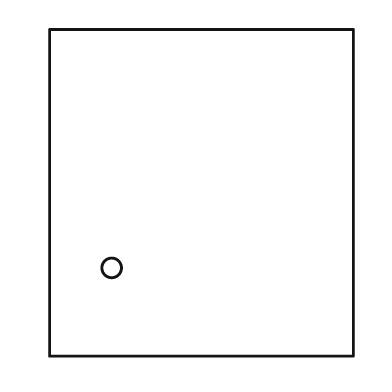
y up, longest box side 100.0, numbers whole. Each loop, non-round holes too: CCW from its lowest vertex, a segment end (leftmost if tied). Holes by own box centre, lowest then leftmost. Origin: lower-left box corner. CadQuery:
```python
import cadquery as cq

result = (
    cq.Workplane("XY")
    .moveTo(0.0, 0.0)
    .lineTo(93.0, 0.0)
    .lineTo(93.0, 100.0)
    .lineTo(0.0, 100.0)
    .close()
    .moveTo(19.0, 27.0)
    .circle(3.0)
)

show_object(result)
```